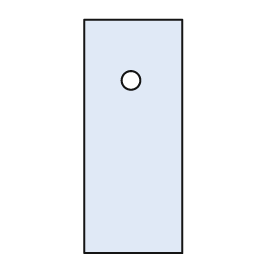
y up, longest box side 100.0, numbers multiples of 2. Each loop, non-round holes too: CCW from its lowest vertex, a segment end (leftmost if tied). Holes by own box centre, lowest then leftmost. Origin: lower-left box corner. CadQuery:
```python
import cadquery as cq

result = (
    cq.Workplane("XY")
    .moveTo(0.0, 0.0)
    .lineTo(42.0, 0.0)
    .lineTo(42.0, 100.0)
    .lineTo(0.0, 100.0)
    .close()
    .moveTo(20.0, 74.0)
    .circle(4.0)
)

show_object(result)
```